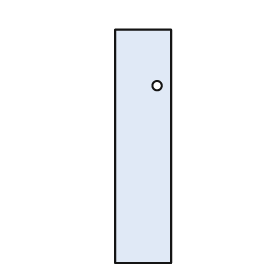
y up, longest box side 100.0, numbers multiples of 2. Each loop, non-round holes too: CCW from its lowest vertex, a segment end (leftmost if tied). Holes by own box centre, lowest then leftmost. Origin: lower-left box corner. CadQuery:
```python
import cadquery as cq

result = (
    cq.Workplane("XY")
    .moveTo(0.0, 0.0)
    .lineTo(24.0, 0.0)
    .lineTo(24.0, 100.0)
    .lineTo(0.0, 100.0)
    .close()
    .moveTo(18.0, 76.0)
    .circle(2.0)
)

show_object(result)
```